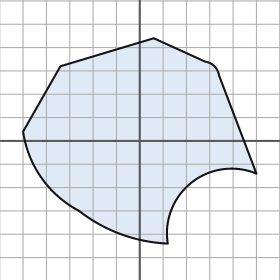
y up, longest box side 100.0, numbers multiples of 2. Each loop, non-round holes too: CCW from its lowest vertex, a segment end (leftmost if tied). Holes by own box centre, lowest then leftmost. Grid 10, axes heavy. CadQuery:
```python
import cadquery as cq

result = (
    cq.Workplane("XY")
    .moveTo(12.0, -44.0)
    .threePointArc((22.0, -18.0), (50.0, -14.0))
    .lineTo(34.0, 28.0)
    .threePointArc((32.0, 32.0), (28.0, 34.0))
    .lineTo(6.0, 44.0)
    .lineTo(-34.0, 32.0)
    .lineTo(-50.0, 4.0)
    .threePointArc((-42.0, -16.0), (-26.0, -30.0))
    .threePointArc((-8.0, -40.0), (12.0, -44.0))
    .close()
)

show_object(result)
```